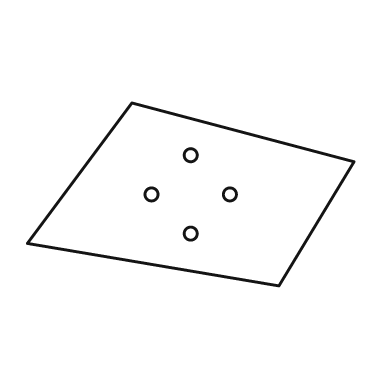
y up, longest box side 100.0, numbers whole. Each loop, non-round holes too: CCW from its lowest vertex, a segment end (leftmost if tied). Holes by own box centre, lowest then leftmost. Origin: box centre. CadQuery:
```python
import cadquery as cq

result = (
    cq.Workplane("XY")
    .moveTo(27.0, -28.0)
    .lineTo(50.0, 10.0)
    .lineTo(-18.0, 28.0)
    .lineTo(-50.0, -15.0)
    .close()
    .moveTo(0.0, -12.0)
    .circle(2.0)
    .moveTo(-12.0, 0.0)
    .circle(2.0)
    .moveTo(12.0, 0.0)
    .circle(2.0)
    .moveTo(0.0, 12.0)
    .circle(2.0)
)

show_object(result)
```